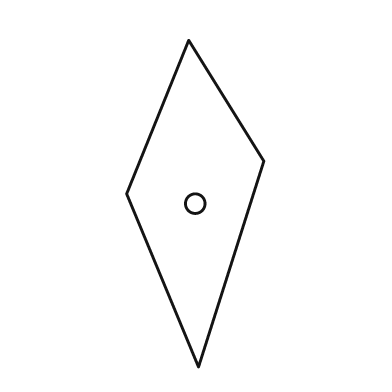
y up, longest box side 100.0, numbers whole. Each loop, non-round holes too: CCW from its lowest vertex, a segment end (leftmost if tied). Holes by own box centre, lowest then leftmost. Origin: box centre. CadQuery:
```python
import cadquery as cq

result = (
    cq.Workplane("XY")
    .moveTo(1.0, -50.0)
    .lineTo(21.0, 13.0)
    .lineTo(-2.0, 50.0)
    .lineTo(-21.0, 3.0)
    .close()
    .moveTo(0.0, 0.0)
    .circle(3.0)
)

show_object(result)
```